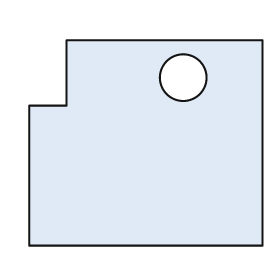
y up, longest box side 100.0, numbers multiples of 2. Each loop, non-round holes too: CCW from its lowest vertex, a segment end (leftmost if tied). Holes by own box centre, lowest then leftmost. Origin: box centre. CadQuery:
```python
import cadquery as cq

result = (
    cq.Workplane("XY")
    .moveTo(-50.0, -44.0)
    .lineTo(50.0, -44.0)
    .lineTo(50.0, 44.0)
    .lineTo(-34.0, 44.0)
    .lineTo(-34.0, 16.0)
    .lineTo(-50.0, 16.0)
    .close()
    .moveTo(16.0, 28.0)
    .circle(10.0)
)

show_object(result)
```